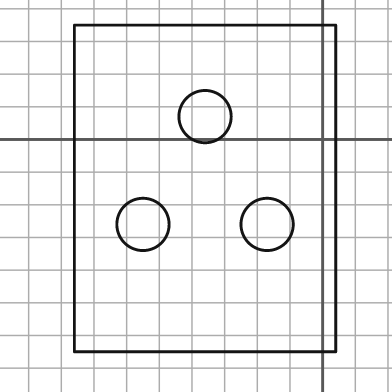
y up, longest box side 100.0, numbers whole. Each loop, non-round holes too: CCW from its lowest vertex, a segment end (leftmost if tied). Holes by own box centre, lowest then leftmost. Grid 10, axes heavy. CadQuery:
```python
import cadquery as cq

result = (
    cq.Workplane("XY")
    .moveTo(-76.0, -65.0)
    .lineTo(4.0, -65.0)
    .lineTo(4.0, 35.0)
    .lineTo(-76.0, 35.0)
    .close()
    .moveTo(-55.0, -26.0)
    .circle(8.0)
    .moveTo(-17.0, -26.0)
    .circle(8.0)
    .moveTo(-36.0, 7.0)
    .circle(8.0)
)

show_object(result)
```